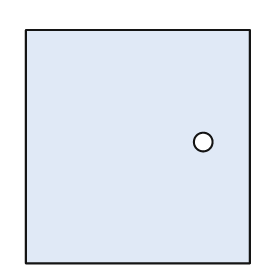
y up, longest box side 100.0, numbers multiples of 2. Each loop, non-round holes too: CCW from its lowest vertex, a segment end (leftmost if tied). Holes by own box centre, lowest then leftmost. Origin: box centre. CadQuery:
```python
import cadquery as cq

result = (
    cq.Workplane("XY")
    .moveTo(-48.0, -50.0)
    .lineTo(48.0, -50.0)
    .lineTo(48.0, 50.0)
    .lineTo(-48.0, 50.0)
    .close()
    .moveTo(28.0, 2.0)
    .circle(4.0)
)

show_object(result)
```